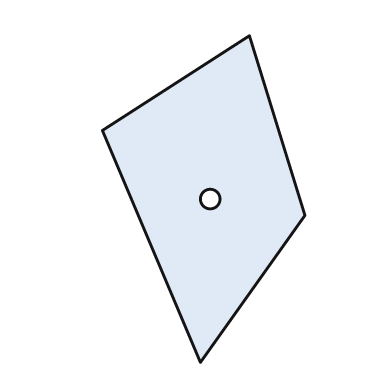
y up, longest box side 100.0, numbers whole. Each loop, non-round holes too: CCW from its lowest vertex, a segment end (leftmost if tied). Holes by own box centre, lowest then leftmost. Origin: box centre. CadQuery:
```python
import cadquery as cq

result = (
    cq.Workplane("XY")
    .moveTo(-1.0, -50.0)
    .lineTo(31.0, -5.0)
    .lineTo(14.0, 50.0)
    .lineTo(-31.0, 21.0)
    .close()
    .moveTo(2.0, 0.0)
    .circle(3.0)
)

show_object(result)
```